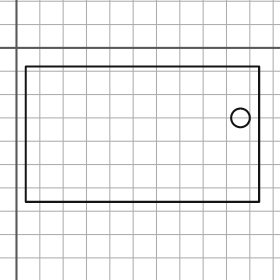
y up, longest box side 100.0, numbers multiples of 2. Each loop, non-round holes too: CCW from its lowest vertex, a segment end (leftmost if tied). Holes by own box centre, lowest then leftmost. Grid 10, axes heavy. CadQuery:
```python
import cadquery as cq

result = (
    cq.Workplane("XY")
    .moveTo(4.0, -66.0)
    .lineTo(104.0, -66.0)
    .lineTo(104.0, -8.0)
    .lineTo(4.0, -8.0)
    .close()
    .moveTo(96.0, -30.0)
    .circle(4.0)
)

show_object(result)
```